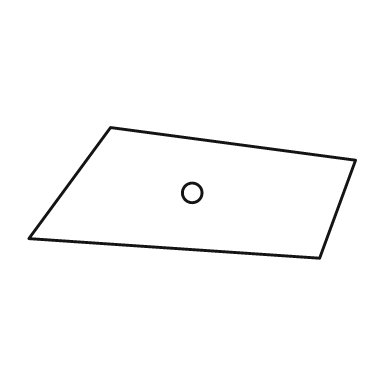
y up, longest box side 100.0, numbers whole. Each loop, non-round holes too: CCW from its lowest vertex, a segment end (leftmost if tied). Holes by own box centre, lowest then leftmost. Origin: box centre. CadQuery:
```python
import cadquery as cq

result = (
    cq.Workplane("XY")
    .moveTo(39.0, -20.0)
    .lineTo(50.0, 10.0)
    .lineTo(-25.0, 20.0)
    .lineTo(-50.0, -14.0)
    .close()
    .moveTo(0.0, 0.0)
    .circle(3.0)
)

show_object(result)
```